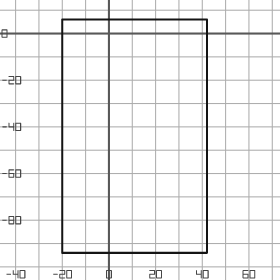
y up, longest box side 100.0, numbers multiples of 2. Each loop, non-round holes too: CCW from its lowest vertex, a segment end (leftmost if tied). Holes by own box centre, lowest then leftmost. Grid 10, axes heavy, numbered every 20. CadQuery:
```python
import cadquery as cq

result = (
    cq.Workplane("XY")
    .moveTo(-20.0, -94.0)
    .lineTo(42.0, -94.0)
    .lineTo(42.0, 6.0)
    .lineTo(-20.0, 6.0)
    .close()
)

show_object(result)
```